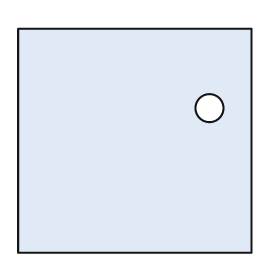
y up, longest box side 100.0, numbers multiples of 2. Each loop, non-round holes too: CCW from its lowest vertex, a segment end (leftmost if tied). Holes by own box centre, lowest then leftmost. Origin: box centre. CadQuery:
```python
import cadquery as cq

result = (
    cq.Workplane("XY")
    .moveTo(-50.0, -48.0)
    .lineTo(50.0, -48.0)
    .lineTo(50.0, 48.0)
    .lineTo(-50.0, 48.0)
    .close()
    .moveTo(32.0, 14.0)
    .circle(6.0)
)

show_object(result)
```